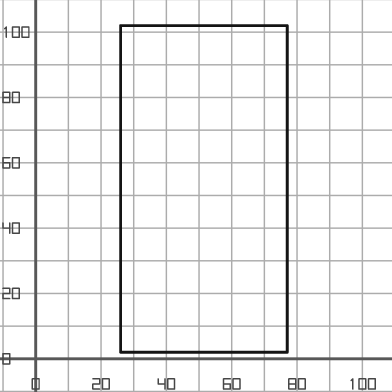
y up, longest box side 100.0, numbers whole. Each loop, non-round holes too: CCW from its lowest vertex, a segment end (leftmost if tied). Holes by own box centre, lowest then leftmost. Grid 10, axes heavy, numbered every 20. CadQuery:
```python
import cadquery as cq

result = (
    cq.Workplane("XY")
    .moveTo(26.0, 2.0)
    .lineTo(77.0, 2.0)
    .lineTo(77.0, 102.0)
    .lineTo(26.0, 102.0)
    .close()
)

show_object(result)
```